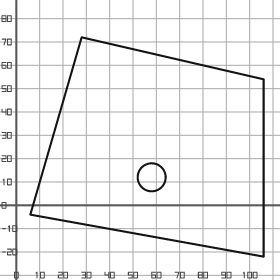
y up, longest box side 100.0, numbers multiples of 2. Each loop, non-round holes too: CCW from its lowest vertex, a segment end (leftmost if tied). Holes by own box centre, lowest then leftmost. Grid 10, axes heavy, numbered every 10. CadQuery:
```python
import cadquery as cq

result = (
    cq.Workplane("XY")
    .moveTo(106.0, -22.0)
    .lineTo(106.0, 54.0)
    .lineTo(28.0, 72.0)
    .lineTo(6.0, -4.0)
    .close()
    .moveTo(58.0, 12.0)
    .circle(6.0)
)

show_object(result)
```